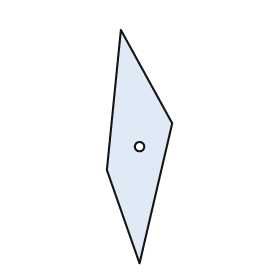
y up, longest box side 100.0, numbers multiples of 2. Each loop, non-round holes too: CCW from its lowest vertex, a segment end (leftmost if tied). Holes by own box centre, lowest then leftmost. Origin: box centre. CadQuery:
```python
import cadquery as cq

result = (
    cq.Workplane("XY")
    .moveTo(0.0, -50.0)
    .lineTo(14.0, 10.0)
    .lineTo(-8.0, 50.0)
    .lineTo(-14.0, -10.0)
    .close()
    .moveTo(0.0, 0.0)
    .circle(2.0)
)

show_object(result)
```